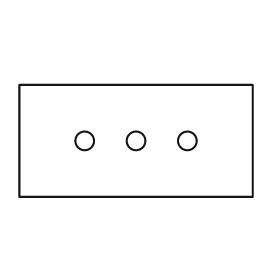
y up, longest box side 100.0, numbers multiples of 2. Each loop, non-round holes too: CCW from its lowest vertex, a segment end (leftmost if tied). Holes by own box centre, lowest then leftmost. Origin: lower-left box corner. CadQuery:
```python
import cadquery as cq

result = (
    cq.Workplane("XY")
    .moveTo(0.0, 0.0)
    .lineTo(100.0, 0.0)
    .lineTo(100.0, 48.0)
    .lineTo(0.0, 48.0)
    .close()
    .moveTo(28.0, 24.0)
    .circle(4.0)
    .moveTo(50.0, 24.0)
    .circle(4.0)
    .moveTo(72.0, 24.0)
    .circle(4.0)
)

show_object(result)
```